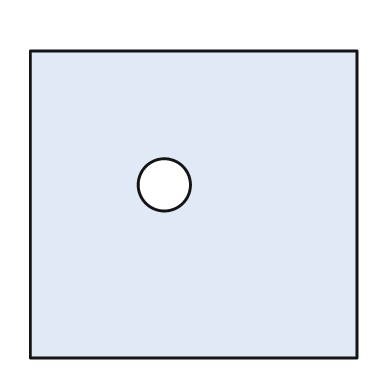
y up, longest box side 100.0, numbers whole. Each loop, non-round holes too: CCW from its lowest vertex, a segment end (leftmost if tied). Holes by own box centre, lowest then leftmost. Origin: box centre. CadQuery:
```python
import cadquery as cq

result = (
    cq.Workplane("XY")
    .moveTo(-50.0, -47.0)
    .lineTo(50.0, -47.0)
    .lineTo(50.0, 47.0)
    .lineTo(-50.0, 47.0)
    .close()
    .moveTo(-9.0, 6.0)
    .circle(8.0)
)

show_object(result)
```